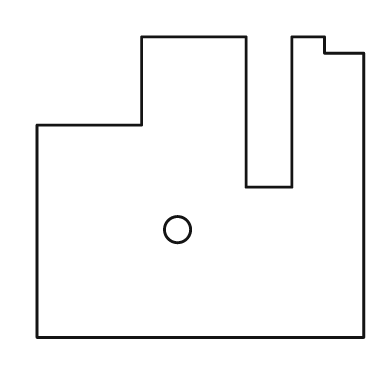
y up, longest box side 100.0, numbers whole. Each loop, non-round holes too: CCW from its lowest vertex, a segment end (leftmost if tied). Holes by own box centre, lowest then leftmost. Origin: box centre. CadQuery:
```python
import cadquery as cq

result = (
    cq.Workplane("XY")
    .moveTo(-50.0, -46.0)
    .lineTo(50.0, -46.0)
    .lineTo(50.0, 41.0)
    .lineTo(38.0, 41.0)
    .lineTo(38.0, 46.0)
    .lineTo(28.0, 46.0)
    .lineTo(28.0, 0.0)
    .lineTo(14.0, 0.0)
    .lineTo(14.0, 46.0)
    .lineTo(-18.0, 46.0)
    .lineTo(-18.0, 19.0)
    .lineTo(-50.0, 19.0)
    .close()
    .moveTo(-7.0, -13.0)
    .circle(4.0)
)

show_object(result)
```